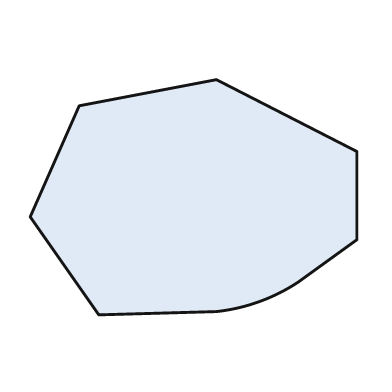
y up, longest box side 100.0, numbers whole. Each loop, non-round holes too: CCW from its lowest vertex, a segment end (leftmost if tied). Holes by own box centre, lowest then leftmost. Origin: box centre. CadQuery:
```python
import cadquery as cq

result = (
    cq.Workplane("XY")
    .moveTo(-29.0, -36.0)
    .lineTo(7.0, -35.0)
    .threePointArc((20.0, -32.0), (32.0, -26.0))
    .lineTo(50.0, -13.0)
    .lineTo(50.0, 14.0)
    .lineTo(7.0, 36.0)
    .lineTo(-35.0, 28.0)
    .lineTo(-50.0, -6.0)
    .close()
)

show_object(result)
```